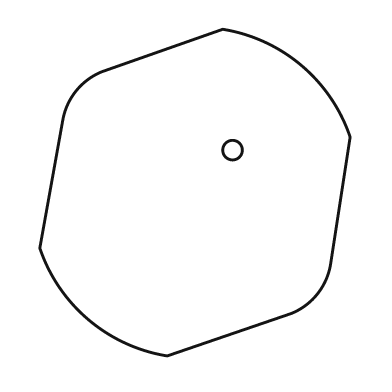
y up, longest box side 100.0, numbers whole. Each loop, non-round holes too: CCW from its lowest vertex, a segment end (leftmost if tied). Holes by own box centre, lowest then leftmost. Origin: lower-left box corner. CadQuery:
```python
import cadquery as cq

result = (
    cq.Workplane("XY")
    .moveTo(39.0, 0.0)
    .lineTo(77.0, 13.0)
    .threePointArc((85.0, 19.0), (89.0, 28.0))
    .lineTo(95.0, 67.0)
    .threePointArc((80.0, 89.0), (56.0, 100.0))
    .lineTo(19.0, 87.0)
    .threePointArc((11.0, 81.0), (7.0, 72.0))
    .lineTo(0.0, 33.0)
    .threePointArc((15.0, 11.0), (39.0, 0.0))
    .close()
    .moveTo(59.0, 63.0)
    .circle(3.0)
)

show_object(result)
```